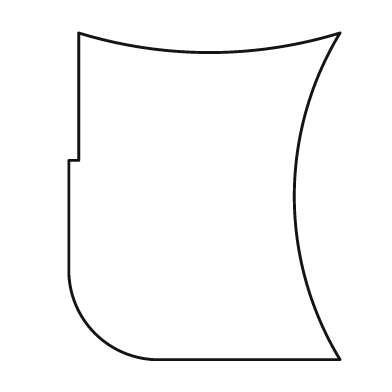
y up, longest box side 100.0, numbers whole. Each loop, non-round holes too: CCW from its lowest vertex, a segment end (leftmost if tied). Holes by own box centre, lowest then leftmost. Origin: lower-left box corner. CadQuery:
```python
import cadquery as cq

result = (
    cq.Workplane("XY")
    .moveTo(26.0, 0.0)
    .lineTo(83.0, 0.0)
    .threePointArc((69.0, 50.0), (83.0, 100.0))
    .threePointArc((43.0, 94.0), (3.0, 100.0))
    .lineTo(3.0, 61.0)
    .lineTo(0.0, 61.0)
    .lineTo(0.0, 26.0)
    .threePointArc((8.0, 8.0), (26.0, 0.0))
    .close()
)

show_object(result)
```